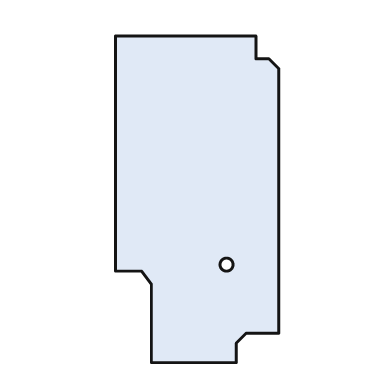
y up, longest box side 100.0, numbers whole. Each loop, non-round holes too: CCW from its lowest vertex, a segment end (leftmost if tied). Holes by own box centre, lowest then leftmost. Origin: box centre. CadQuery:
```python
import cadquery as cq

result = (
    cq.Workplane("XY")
    .moveTo(-14.0, -50.0)
    .lineTo(12.0, -50.0)
    .lineTo(12.0, -44.0)
    .lineTo(15.0, -41.0)
    .lineTo(25.0, -41.0)
    .lineTo(25.0, 40.0)
    .lineTo(22.0, 43.0)
    .lineTo(18.0, 43.0)
    .lineTo(18.0, 50.0)
    .lineTo(-25.0, 50.0)
    .lineTo(-25.0, -22.0)
    .lineTo(-17.0, -22.0)
    .lineTo(-14.0, -26.0)
    .close()
    .moveTo(9.0, -20.0)
    .circle(2.0)
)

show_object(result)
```